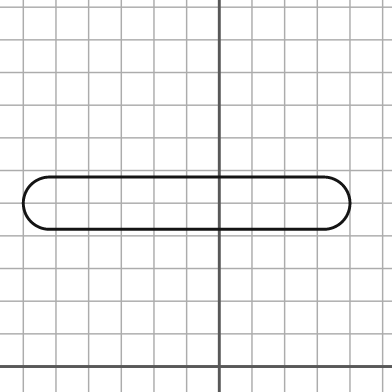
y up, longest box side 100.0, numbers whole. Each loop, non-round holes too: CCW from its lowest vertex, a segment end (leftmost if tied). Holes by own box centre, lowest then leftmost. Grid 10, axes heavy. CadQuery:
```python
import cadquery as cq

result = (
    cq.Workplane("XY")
    .moveTo(-52.0, 42.0)
    .lineTo(32.0, 42.0)
    .threePointArc((40.0, 50.0), (32.0, 58.0))
    .lineTo(-52.0, 58.0)
    .threePointArc((-60.0, 50.0), (-52.0, 42.0))
    .close()
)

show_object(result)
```